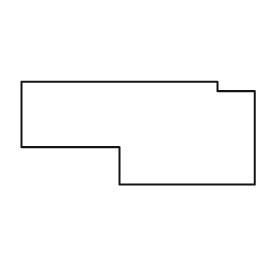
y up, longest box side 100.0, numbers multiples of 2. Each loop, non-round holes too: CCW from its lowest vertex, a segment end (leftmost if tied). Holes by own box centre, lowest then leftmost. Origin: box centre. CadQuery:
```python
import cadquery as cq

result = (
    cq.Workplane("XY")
    .moveTo(-8.0, -22.0)
    .lineTo(50.0, -22.0)
    .lineTo(50.0, 18.0)
    .lineTo(34.0, 18.0)
    .lineTo(34.0, 22.0)
    .lineTo(-50.0, 22.0)
    .lineTo(-50.0, -6.0)
    .lineTo(-8.0, -6.0)
    .close()
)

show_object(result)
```